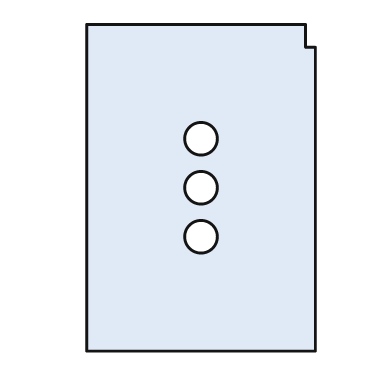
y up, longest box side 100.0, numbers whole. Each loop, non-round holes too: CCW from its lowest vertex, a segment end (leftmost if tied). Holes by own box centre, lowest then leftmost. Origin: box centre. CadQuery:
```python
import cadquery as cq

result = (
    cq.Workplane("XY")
    .moveTo(-35.0, -50.0)
    .lineTo(35.0, -50.0)
    .lineTo(35.0, 43.0)
    .lineTo(32.0, 43.0)
    .lineTo(32.0, 50.0)
    .lineTo(-35.0, 50.0)
    .close()
    .moveTo(0.0, -15.0)
    .circle(5.0)
    .moveTo(0.0, 0.0)
    .circle(5.0)
    .moveTo(0.0, 15.0)
    .circle(5.0)
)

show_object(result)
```